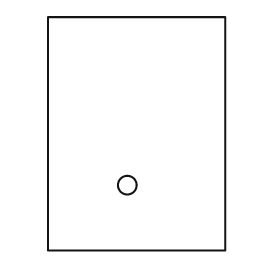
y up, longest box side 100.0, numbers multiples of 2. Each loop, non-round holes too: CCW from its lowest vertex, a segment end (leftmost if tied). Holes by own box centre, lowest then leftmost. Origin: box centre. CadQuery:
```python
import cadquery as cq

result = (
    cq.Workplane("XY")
    .moveTo(-38.0, -50.0)
    .lineTo(38.0, -50.0)
    .lineTo(38.0, 50.0)
    .lineTo(-38.0, 50.0)
    .close()
    .moveTo(-4.0, -22.0)
    .circle(4.0)
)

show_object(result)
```